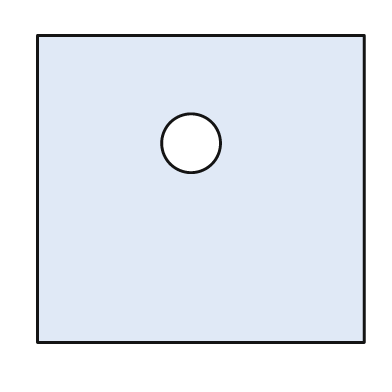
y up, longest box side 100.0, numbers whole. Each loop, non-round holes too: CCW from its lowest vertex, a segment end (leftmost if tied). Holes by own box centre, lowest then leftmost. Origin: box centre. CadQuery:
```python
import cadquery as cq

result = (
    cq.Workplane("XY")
    .moveTo(-50.0, -47.0)
    .lineTo(50.0, -47.0)
    .lineTo(50.0, 47.0)
    .lineTo(-50.0, 47.0)
    .close()
    .moveTo(-3.0, 14.0)
    .circle(9.0)
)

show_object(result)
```